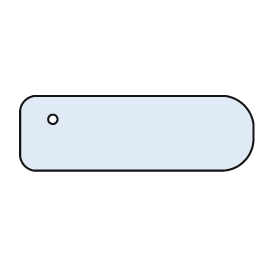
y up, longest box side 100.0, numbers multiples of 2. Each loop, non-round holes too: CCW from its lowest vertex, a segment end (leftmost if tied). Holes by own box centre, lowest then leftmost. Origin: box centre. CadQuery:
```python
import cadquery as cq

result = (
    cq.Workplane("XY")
    .moveTo(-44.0, -16.0)
    .lineTo(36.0, -16.0)
    .threePointArc((46.0, -12.0), (50.0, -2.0))
    .lineTo(50.0, 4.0)
    .threePointArc((46.0, 12.0), (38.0, 16.0))
    .lineTo(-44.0, 16.0)
    .threePointArc((-48.0, 14.0), (-50.0, 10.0))
    .lineTo(-50.0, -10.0)
    .threePointArc((-48.0, -14.0), (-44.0, -16.0))
    .close()
    .moveTo(-36.0, 6.0)
    .circle(2.0)
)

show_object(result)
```